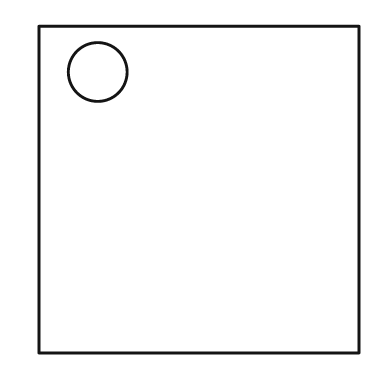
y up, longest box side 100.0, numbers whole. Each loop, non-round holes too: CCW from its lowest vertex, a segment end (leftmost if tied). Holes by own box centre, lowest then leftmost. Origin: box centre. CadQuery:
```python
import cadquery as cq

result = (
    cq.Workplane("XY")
    .moveTo(-49.0, -50.0)
    .lineTo(49.0, -50.0)
    .lineTo(49.0, 50.0)
    .lineTo(-49.0, 50.0)
    .close()
    .moveTo(-31.0, 36.0)
    .circle(9.0)
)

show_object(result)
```